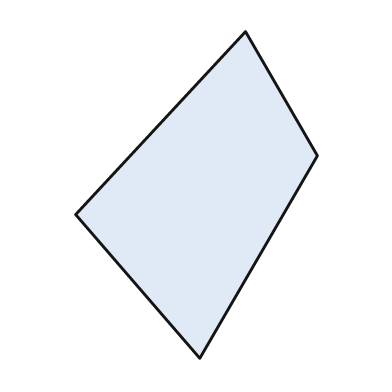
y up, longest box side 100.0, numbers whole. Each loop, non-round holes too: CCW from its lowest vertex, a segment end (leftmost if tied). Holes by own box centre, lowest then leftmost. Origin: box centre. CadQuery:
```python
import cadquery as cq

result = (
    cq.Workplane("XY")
    .moveTo(1.0, -50.0)
    .lineTo(37.0, 12.0)
    .lineTo(15.0, 50.0)
    .lineTo(-37.0, -6.0)
    .close()
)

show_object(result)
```